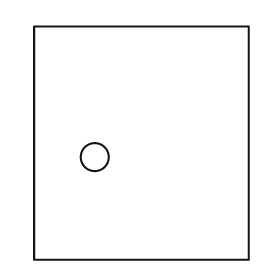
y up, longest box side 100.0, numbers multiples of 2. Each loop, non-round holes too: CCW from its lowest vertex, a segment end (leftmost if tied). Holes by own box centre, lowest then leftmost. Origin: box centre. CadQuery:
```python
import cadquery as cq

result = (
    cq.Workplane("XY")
    .moveTo(-46.0, -50.0)
    .lineTo(46.0, -50.0)
    .lineTo(46.0, 50.0)
    .lineTo(-46.0, 50.0)
    .close()
    .moveTo(-20.0, -6.0)
    .circle(6.0)
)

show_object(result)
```